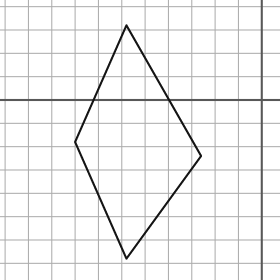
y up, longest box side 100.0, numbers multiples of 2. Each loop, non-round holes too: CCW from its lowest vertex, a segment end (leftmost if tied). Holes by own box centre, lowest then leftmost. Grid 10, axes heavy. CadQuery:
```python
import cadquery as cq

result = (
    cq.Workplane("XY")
    .moveTo(-58.0, -68.0)
    .lineTo(-26.0, -24.0)
    .lineTo(-58.0, 32.0)
    .lineTo(-80.0, -18.0)
    .close()
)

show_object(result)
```